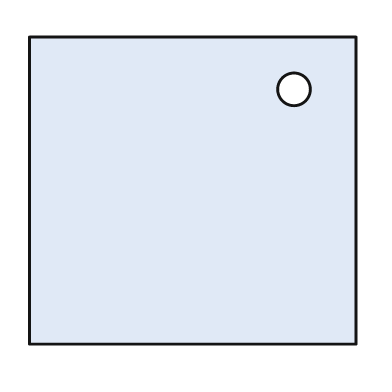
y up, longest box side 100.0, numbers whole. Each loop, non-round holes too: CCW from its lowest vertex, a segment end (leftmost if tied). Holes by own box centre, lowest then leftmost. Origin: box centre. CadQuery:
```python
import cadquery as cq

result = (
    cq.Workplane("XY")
    .moveTo(-50.0, -47.0)
    .lineTo(50.0, -47.0)
    .lineTo(50.0, 47.0)
    .lineTo(-50.0, 47.0)
    .close()
    .moveTo(31.0, 31.0)
    .circle(5.0)
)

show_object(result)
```